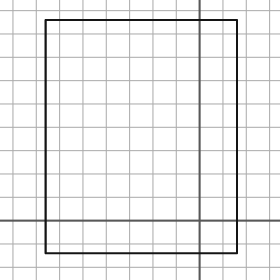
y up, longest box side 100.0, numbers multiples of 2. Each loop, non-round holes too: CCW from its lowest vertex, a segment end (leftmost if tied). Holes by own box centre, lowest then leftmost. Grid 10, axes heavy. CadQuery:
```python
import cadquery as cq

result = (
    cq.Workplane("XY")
    .moveTo(-66.0, -14.0)
    .lineTo(16.0, -14.0)
    .lineTo(16.0, 86.0)
    .lineTo(-66.0, 86.0)
    .close()
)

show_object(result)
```